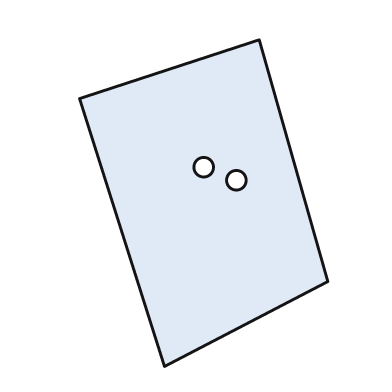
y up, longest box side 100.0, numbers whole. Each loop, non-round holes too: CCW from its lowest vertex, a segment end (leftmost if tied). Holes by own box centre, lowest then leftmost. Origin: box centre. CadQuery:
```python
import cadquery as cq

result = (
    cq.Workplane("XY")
    .moveTo(-12.0, -50.0)
    .lineTo(38.0, -24.0)
    .lineTo(17.0, 50.0)
    .lineTo(-38.0, 32.0)
    .close()
    .moveTo(10.0, 7.0)
    .circle(3.0)
    .moveTo(0.0, 11.0)
    .circle(3.0)
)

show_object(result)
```